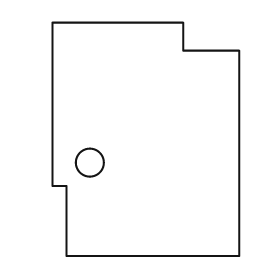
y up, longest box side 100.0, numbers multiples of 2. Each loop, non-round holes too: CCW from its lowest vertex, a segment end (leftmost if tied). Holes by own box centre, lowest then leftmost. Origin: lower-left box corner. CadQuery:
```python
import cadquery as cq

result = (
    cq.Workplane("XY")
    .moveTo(6.0, 0.0)
    .lineTo(80.0, 0.0)
    .lineTo(80.0, 88.0)
    .lineTo(56.0, 88.0)
    .lineTo(56.0, 100.0)
    .lineTo(0.0, 100.0)
    .lineTo(0.0, 30.0)
    .lineTo(6.0, 30.0)
    .close()
    .moveTo(16.0, 40.0)
    .circle(6.0)
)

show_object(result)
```